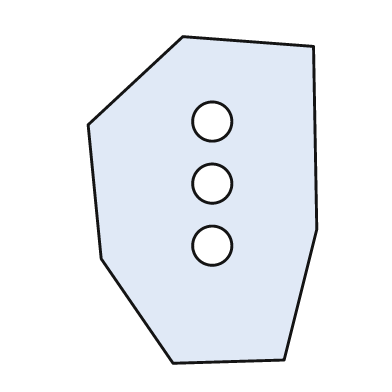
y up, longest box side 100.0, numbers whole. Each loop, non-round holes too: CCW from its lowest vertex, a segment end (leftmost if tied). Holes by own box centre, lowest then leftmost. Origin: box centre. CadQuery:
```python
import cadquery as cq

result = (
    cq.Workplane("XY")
    .moveTo(-9.0, -50.0)
    .lineTo(25.0, -49.0)
    .lineTo(35.0, -9.0)
    .lineTo(34.0, 47.0)
    .lineTo(-6.0, 50.0)
    .lineTo(-35.0, 23.0)
    .lineTo(-31.0, -18.0)
    .close()
    .moveTo(3.0, -14.0)
    .circle(6.0)
    .moveTo(3.0, 5.0)
    .circle(6.0)
    .moveTo(3.0, 24.0)
    .circle(6.0)
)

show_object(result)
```